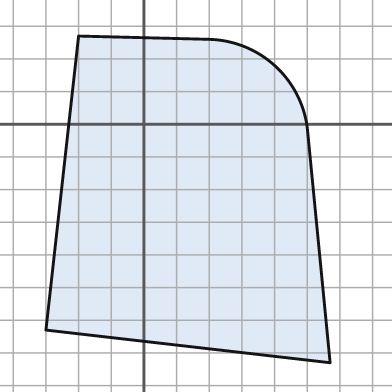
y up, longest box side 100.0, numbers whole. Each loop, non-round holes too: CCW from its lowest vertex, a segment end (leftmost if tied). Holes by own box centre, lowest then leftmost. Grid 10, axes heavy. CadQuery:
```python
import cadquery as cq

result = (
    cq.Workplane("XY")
    .moveTo(57.0, -73.0)
    .lineTo(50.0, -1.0)
    .threePointArc((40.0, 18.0), (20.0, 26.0))
    .lineTo(-20.0, 27.0)
    .lineTo(-30.0, -63.0)
    .close()
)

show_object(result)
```